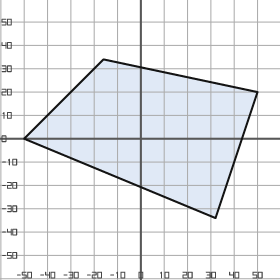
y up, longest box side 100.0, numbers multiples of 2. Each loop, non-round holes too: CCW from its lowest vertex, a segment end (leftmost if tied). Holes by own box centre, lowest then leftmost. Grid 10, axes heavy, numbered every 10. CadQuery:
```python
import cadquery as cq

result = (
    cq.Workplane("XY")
    .moveTo(32.0, -34.0)
    .lineTo(50.0, 20.0)
    .lineTo(-16.0, 34.0)
    .lineTo(-50.0, 0.0)
    .close()
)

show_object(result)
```